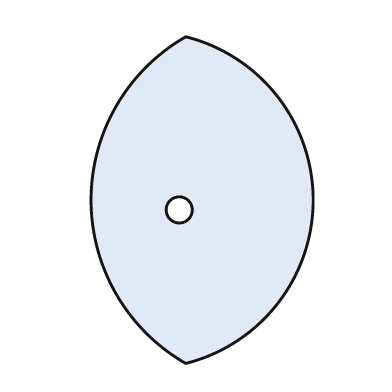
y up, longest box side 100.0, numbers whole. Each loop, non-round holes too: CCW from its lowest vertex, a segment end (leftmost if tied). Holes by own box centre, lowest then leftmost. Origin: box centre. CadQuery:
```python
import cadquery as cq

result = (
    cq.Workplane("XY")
    .moveTo(-5.0, -50.0)
    .threePointArc((34.0, 0.0), (-5.0, 50.0))
    .threePointArc((-34.0, 0.0), (-5.0, -50.0))
    .close()
    .moveTo(-7.0, -3.0)
    .circle(4.0)
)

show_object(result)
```